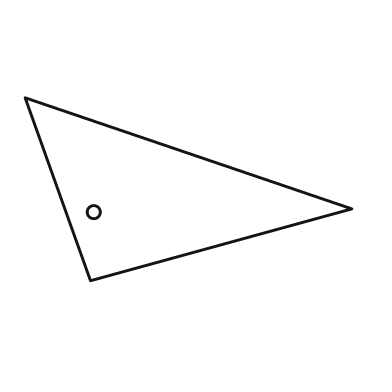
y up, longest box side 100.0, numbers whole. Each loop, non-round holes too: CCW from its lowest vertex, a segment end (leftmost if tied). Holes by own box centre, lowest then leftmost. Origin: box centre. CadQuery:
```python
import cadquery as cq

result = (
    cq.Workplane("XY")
    .moveTo(-30.0, -28.0)
    .lineTo(50.0, -6.0)
    .lineTo(-50.0, 28.0)
    .close()
    .moveTo(-29.0, -7.0)
    .circle(2.0)
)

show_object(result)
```